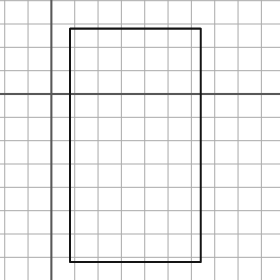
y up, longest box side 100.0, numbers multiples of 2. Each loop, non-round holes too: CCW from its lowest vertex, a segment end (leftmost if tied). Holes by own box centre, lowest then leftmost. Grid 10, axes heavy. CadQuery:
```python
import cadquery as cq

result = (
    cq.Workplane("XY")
    .moveTo(8.0, -72.0)
    .lineTo(64.0, -72.0)
    .lineTo(64.0, 28.0)
    .lineTo(8.0, 28.0)
    .close()
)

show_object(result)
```